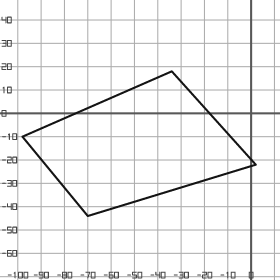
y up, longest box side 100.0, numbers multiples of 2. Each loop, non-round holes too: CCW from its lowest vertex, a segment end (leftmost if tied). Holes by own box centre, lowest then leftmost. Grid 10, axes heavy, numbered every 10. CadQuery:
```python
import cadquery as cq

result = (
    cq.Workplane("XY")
    .moveTo(-70.0, -44.0)
    .lineTo(2.0, -22.0)
    .lineTo(-34.0, 18.0)
    .lineTo(-98.0, -10.0)
    .close()
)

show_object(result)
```